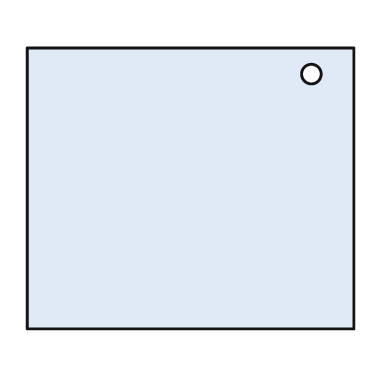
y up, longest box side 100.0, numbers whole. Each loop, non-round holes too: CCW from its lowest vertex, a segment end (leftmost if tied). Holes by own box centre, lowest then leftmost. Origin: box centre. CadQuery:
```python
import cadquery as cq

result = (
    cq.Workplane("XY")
    .moveTo(-50.0, -43.0)
    .lineTo(50.0, -43.0)
    .lineTo(50.0, 43.0)
    .lineTo(-50.0, 43.0)
    .close()
    .moveTo(37.0, 35.0)
    .circle(3.0)
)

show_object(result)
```